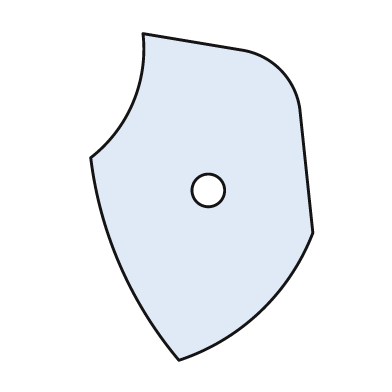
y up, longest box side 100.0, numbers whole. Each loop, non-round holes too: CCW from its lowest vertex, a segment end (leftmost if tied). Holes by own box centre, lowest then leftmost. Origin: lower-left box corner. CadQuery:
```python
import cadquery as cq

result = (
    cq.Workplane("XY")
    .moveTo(27.0, 0.0)
    .threePointArc((52.0, 15.0), (68.0, 39.0))
    .lineTo(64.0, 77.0)
    .threePointArc((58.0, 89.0), (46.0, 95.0))
    .lineTo(16.0, 100.0)
    .threePointArc((13.0, 79.0), (0.0, 62.0))
    .threePointArc((9.0, 29.0), (27.0, 0.0))
    .close()
    .moveTo(36.0, 52.0)
    .circle(5.0)
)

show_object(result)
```